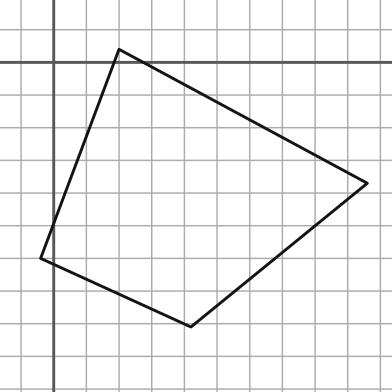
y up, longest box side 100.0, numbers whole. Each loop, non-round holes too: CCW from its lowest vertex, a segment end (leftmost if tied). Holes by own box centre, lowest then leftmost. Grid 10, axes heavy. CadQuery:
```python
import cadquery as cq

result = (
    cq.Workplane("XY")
    .moveTo(42.0, -81.0)
    .lineTo(96.0, -37.0)
    .lineTo(20.0, 4.0)
    .lineTo(-4.0, -60.0)
    .close()
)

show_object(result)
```